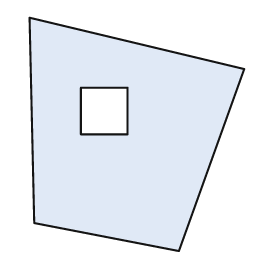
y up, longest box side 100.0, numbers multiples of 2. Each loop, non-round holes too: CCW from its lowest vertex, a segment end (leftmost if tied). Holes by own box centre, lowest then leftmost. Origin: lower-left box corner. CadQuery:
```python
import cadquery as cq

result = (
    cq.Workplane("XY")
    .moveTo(64.0, 0.0)
    .lineTo(92.0, 78.0)
    .lineTo(0.0, 100.0)
    .lineTo(2.0, 12.0)
    .close()
    .moveTo(22.0, 50.0)
    .lineTo(42.0, 50.0)
    .lineTo(42.0, 70.0)
    .lineTo(22.0, 70.0)
    .close()
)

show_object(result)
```